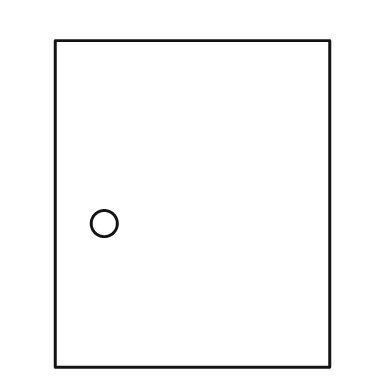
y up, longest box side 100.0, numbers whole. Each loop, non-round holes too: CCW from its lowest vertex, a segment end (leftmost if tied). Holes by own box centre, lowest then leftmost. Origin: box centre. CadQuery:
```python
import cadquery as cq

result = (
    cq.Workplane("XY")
    .moveTo(-42.0, -50.0)
    .lineTo(42.0, -50.0)
    .lineTo(42.0, 50.0)
    .lineTo(-42.0, 50.0)
    .close()
    .moveTo(-27.0, -6.0)
    .circle(4.0)
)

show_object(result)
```